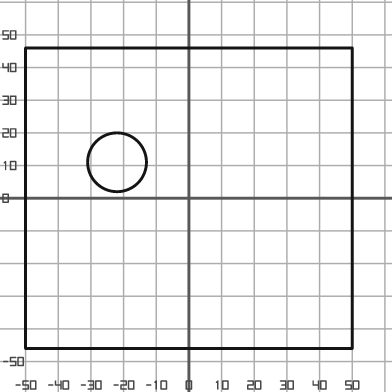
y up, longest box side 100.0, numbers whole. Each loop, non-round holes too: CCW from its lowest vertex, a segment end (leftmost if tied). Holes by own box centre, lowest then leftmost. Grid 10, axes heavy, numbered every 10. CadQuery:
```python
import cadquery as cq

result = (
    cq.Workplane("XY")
    .moveTo(-50.0, -46.0)
    .lineTo(50.0, -46.0)
    .lineTo(50.0, 46.0)
    .lineTo(-50.0, 46.0)
    .close()
    .moveTo(-22.0, 11.0)
    .circle(9.0)
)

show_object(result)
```